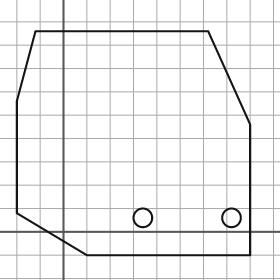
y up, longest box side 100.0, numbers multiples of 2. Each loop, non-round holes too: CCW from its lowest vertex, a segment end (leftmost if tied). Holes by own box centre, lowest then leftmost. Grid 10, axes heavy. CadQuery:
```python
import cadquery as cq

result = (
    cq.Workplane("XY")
    .moveTo(10.0, -10.0)
    .lineTo(80.0, -10.0)
    .lineTo(80.0, 46.0)
    .lineTo(62.0, 86.0)
    .lineTo(-12.0, 86.0)
    .lineTo(-20.0, 56.0)
    .lineTo(-20.0, 8.0)
    .close()
    .moveTo(34.0, 6.0)
    .circle(4.0)
    .moveTo(72.0, 6.0)
    .circle(4.0)
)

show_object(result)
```